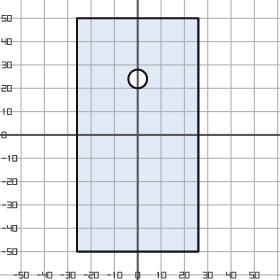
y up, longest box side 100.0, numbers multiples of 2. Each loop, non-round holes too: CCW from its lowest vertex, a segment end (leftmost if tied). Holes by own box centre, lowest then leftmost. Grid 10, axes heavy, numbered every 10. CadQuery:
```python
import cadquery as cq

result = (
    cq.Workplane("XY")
    .moveTo(-26.0, -50.0)
    .lineTo(26.0, -50.0)
    .lineTo(26.0, 50.0)
    .lineTo(-26.0, 50.0)
    .close()
    .moveTo(0.0, 24.0)
    .circle(4.0)
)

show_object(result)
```